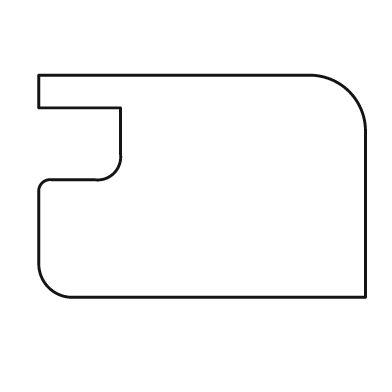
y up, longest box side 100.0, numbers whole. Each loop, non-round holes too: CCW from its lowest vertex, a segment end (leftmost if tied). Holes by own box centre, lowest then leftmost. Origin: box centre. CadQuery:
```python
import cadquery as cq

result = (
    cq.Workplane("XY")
    .moveTo(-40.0, -34.0)
    .lineTo(50.0, -34.0)
    .lineTo(50.0, 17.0)
    .threePointArc((45.0, 29.0), (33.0, 34.0))
    .lineTo(-50.0, 34.0)
    .lineTo(-50.0, 24.0)
    .lineTo(-25.0, 24.0)
    .lineTo(-25.0, 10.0)
    .threePointArc((-27.0, 4.0), (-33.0, 2.0))
    .lineTo(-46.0, 2.0)
    .threePointArc((-49.0, 1.0), (-50.0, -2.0))
    .lineTo(-50.0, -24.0)
    .threePointArc((-47.0, -31.0), (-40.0, -34.0))
    .close()
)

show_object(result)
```